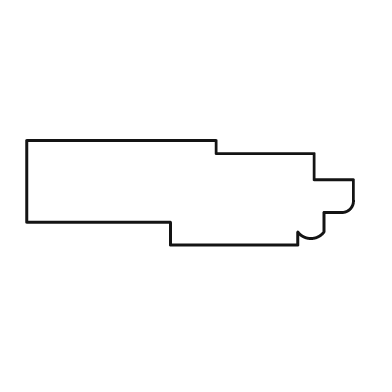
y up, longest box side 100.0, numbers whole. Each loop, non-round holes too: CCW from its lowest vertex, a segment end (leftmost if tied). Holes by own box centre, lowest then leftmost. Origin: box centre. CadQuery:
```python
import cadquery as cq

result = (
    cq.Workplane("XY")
    .moveTo(-6.0, -16.0)
    .lineTo(33.0, -16.0)
    .lineTo(33.0, -12.0)
    .threePointArc((37.0, -14.0), (41.0, -12.0))
    .lineTo(41.0, -6.0)
    .lineTo(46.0, -6.0)
    .threePointArc((49.0, -5.0), (50.0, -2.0))
    .lineTo(50.0, 4.0)
    .lineTo(38.0, 4.0)
    .lineTo(38.0, 12.0)
    .lineTo(8.0, 12.0)
    .lineTo(8.0, 16.0)
    .lineTo(-50.0, 16.0)
    .lineTo(-50.0, -9.0)
    .lineTo(-6.0, -9.0)
    .close()
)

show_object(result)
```